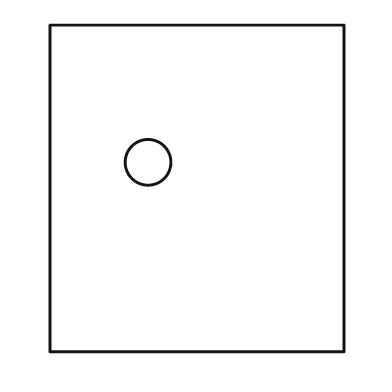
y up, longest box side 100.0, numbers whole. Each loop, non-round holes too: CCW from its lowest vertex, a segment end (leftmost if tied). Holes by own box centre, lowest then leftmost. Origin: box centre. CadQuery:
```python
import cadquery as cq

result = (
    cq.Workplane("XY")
    .moveTo(-45.0, -50.0)
    .lineTo(45.0, -50.0)
    .lineTo(45.0, 50.0)
    .lineTo(-45.0, 50.0)
    .close()
    .moveTo(-15.0, 8.0)
    .circle(7.0)
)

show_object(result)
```